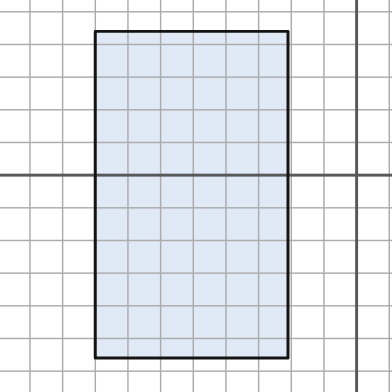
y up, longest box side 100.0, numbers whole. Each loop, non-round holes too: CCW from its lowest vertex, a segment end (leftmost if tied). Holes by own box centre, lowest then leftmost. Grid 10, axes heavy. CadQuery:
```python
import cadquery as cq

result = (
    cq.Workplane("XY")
    .moveTo(-80.0, -56.0)
    .lineTo(-21.0, -56.0)
    .lineTo(-21.0, 44.0)
    .lineTo(-80.0, 44.0)
    .close()
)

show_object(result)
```